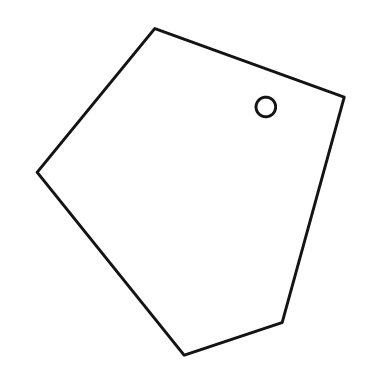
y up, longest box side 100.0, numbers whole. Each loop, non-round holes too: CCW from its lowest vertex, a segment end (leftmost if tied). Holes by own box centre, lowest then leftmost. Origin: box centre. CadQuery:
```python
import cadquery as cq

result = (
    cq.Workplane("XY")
    .moveTo(-2.0, -50.0)
    .lineTo(28.0, -40.0)
    .lineTo(47.0, 29.0)
    .lineTo(-11.0, 50.0)
    .lineTo(-47.0, 6.0)
    .close()
    .moveTo(23.0, 26.0)
    .circle(3.0)
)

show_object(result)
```